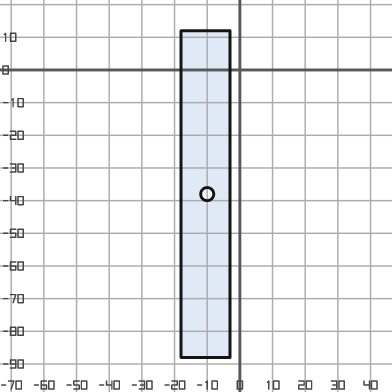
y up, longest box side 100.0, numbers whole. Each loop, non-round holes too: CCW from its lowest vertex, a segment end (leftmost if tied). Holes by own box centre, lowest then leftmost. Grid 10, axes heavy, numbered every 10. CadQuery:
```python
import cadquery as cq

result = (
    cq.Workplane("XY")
    .moveTo(-18.0, -88.0)
    .lineTo(-3.0, -88.0)
    .lineTo(-3.0, 12.0)
    .lineTo(-18.0, 12.0)
    .close()
    .moveTo(-10.0, -38.0)
    .circle(2.0)
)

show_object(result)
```